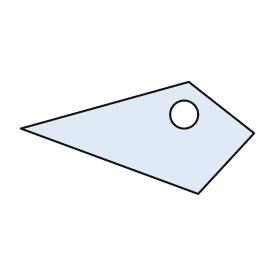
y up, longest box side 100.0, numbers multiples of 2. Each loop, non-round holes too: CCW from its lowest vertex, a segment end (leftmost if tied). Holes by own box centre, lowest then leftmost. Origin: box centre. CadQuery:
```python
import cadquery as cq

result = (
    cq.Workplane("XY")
    .moveTo(26.0, -24.0)
    .lineTo(50.0, 2.0)
    .lineTo(22.0, 24.0)
    .lineTo(-50.0, 4.0)
    .close()
    .moveTo(20.0, 10.0)
    .circle(6.0)
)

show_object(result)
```